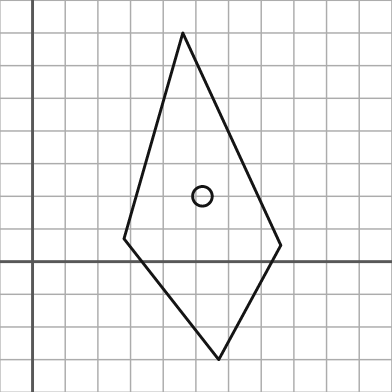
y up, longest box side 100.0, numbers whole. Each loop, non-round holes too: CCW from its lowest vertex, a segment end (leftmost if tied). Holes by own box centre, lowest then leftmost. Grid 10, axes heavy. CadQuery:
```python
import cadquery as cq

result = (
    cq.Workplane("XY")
    .moveTo(57.0, -30.0)
    .lineTo(76.0, 5.0)
    .lineTo(46.0, 70.0)
    .lineTo(28.0, 7.0)
    .close()
    .moveTo(52.0, 20.0)
    .circle(3.0)
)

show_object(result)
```